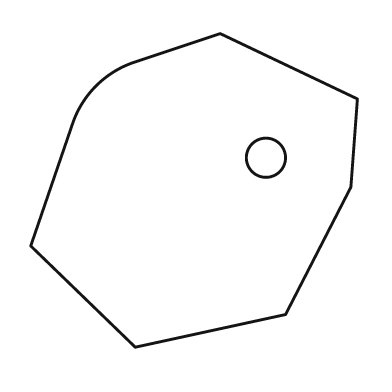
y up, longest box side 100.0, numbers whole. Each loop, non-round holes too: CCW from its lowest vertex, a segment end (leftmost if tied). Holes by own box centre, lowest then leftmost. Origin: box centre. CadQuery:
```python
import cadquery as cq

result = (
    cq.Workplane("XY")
    .moveTo(-18.0, -48.0)
    .lineTo(28.0, -38.0)
    .lineTo(48.0, 1.0)
    .lineTo(50.0, 28.0)
    .lineTo(8.0, 48.0)
    .lineTo(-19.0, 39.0)
    .threePointArc((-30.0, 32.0), (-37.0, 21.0))
    .lineTo(-50.0, -17.0)
    .close()
    .moveTo(22.0, 10.0)
    .circle(6.0)
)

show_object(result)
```